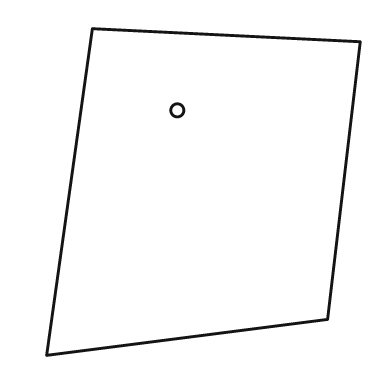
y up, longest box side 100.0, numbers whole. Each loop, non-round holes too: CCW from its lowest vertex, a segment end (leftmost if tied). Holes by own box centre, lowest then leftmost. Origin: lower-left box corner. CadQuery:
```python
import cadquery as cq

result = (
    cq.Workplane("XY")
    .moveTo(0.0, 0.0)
    .lineTo(86.0, 11.0)
    .lineTo(96.0, 96.0)
    .lineTo(14.0, 100.0)
    .close()
    .moveTo(40.0, 75.0)
    .circle(2.0)
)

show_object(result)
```